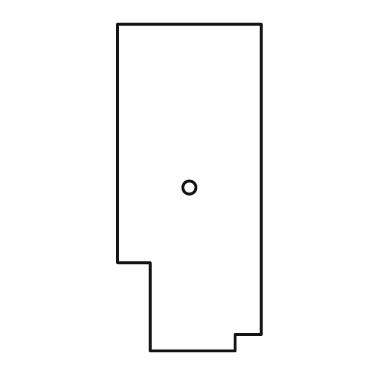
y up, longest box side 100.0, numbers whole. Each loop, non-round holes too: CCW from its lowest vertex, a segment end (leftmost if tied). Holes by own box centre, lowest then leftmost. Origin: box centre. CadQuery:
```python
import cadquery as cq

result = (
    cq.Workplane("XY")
    .moveTo(-12.0, -50.0)
    .lineTo(14.0, -50.0)
    .lineTo(14.0, -45.0)
    .lineTo(22.0, -45.0)
    .lineTo(22.0, 50.0)
    .lineTo(-22.0, 50.0)
    .lineTo(-22.0, -23.0)
    .lineTo(-12.0, -23.0)
    .close()
    .moveTo(0.0, 0.0)
    .circle(2.0)
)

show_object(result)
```